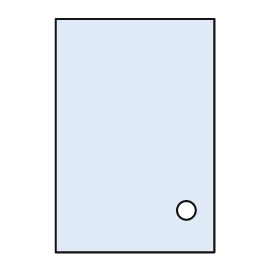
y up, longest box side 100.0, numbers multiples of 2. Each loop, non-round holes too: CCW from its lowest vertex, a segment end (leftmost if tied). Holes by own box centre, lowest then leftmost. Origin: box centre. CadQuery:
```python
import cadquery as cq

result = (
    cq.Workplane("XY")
    .moveTo(-34.0, -50.0)
    .lineTo(34.0, -50.0)
    .lineTo(34.0, 50.0)
    .lineTo(-34.0, 50.0)
    .close()
    .moveTo(22.0, -32.0)
    .circle(4.0)
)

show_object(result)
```